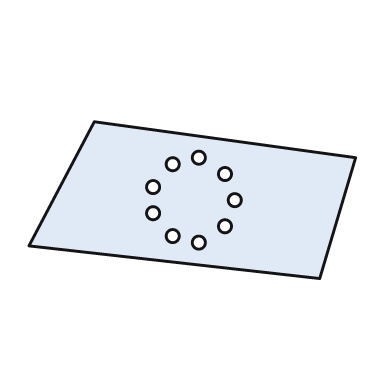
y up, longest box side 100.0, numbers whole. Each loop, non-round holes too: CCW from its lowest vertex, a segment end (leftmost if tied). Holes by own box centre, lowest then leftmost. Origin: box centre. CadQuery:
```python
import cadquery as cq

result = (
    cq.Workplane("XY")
    .moveTo(39.0, -24.0)
    .lineTo(50.0, 13.0)
    .lineTo(-30.0, 24.0)
    .lineTo(-50.0, -14.0)
    .close()
    .moveTo(2.0, -13.0)
    .circle(2.0)
    .moveTo(-6.0, -11.0)
    .circle(2.0)
    .moveTo(10.0, -8.0)
    .circle(2.0)
    .moveTo(-12.0, -4.0)
    .circle(2.0)
    .moveTo(13.0, 0.0)
    .circle(2.0)
    .moveTo(-12.0, 4.0)
    .circle(2.0)
    .moveTo(10.0, 8.0)
    .circle(2.0)
    .moveTo(-6.0, 11.0)
    .circle(2.0)
    .moveTo(2.0, 13.0)
    .circle(2.0)
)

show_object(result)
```